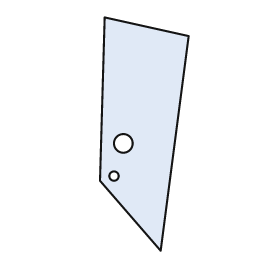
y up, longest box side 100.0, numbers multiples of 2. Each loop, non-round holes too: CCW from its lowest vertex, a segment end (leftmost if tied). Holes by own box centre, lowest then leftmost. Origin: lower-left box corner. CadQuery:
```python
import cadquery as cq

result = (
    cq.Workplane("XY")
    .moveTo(26.0, 0.0)
    .lineTo(38.0, 92.0)
    .lineTo(2.0, 100.0)
    .lineTo(0.0, 30.0)
    .close()
    .moveTo(6.0, 32.0)
    .circle(2.0)
    .moveTo(10.0, 46.0)
    .circle(4.0)
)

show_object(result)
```